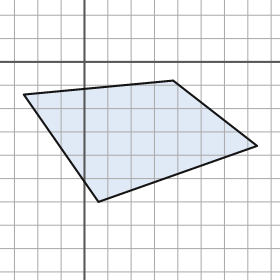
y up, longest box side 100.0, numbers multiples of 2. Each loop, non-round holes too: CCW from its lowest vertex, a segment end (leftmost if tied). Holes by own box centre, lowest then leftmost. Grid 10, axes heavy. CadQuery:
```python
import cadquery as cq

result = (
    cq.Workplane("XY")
    .moveTo(6.0, -60.0)
    .lineTo(74.0, -36.0)
    .lineTo(38.0, -8.0)
    .lineTo(-26.0, -14.0)
    .close()
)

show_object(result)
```